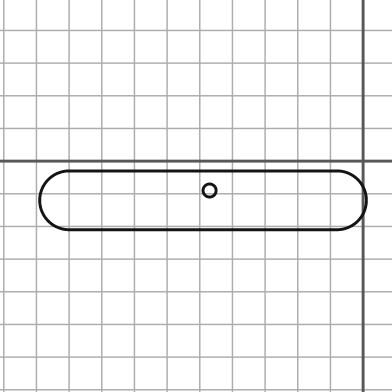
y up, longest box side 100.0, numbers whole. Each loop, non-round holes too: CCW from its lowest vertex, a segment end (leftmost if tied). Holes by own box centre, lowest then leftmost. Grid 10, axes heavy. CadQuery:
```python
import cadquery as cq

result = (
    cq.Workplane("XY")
    .moveTo(-90.0, -21.0)
    .lineTo(-8.0, -21.0)
    .threePointArc((1.0, -12.0), (-8.0, -3.0))
    .lineTo(-90.0, -3.0)
    .threePointArc((-99.0, -12.0), (-90.0, -21.0))
    .close()
    .moveTo(-47.0, -9.0)
    .circle(2.0)
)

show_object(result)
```